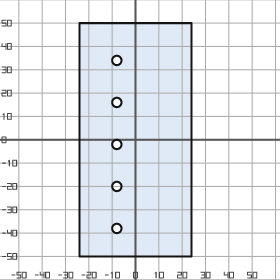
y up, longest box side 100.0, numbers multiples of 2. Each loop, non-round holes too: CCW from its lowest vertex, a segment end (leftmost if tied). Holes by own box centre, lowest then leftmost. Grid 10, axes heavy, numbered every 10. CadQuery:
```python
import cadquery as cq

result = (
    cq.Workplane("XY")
    .moveTo(-24.0, -50.0)
    .lineTo(24.0, -50.0)
    .lineTo(24.0, 50.0)
    .lineTo(-24.0, 50.0)
    .close()
    .moveTo(-8.0, -38.0)
    .circle(2.0)
    .moveTo(-8.0, -20.0)
    .circle(2.0)
    .moveTo(-8.0, -2.0)
    .circle(2.0)
    .moveTo(-8.0, 16.0)
    .circle(2.0)
    .moveTo(-8.0, 34.0)
    .circle(2.0)
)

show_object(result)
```